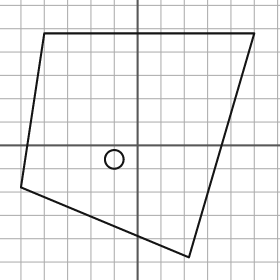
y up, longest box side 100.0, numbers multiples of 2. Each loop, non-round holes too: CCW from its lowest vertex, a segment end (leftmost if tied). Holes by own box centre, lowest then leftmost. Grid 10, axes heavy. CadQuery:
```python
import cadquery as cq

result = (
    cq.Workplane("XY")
    .moveTo(22.0, -48.0)
    .lineTo(50.0, 48.0)
    .lineTo(-40.0, 48.0)
    .lineTo(-50.0, -18.0)
    .close()
    .moveTo(-10.0, -6.0)
    .circle(4.0)
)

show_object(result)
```